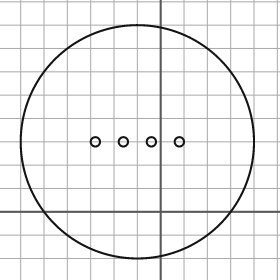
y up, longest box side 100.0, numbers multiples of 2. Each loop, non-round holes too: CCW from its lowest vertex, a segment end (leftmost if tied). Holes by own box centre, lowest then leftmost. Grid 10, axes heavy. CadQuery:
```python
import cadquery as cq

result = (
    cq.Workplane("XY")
    .moveTo(-10.0, 30.0)
    .circle(50.0)
    .moveTo(-28.0, 30.0)
    .circle(2.0)
    .moveTo(-16.0, 30.0)
    .circle(2.0)
    .moveTo(-4.0, 30.0)
    .circle(2.0)
    .moveTo(8.0, 30.0)
    .circle(2.0)
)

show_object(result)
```